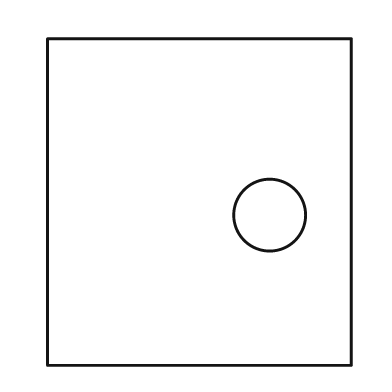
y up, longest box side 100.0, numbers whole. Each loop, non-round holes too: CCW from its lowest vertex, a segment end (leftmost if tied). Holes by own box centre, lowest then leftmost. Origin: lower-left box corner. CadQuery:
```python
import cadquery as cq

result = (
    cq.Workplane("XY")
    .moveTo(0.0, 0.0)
    .lineTo(93.0, 0.0)
    .lineTo(93.0, 100.0)
    .lineTo(0.0, 100.0)
    .close()
    .moveTo(68.0, 46.0)
    .circle(11.0)
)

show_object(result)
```